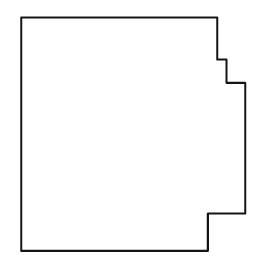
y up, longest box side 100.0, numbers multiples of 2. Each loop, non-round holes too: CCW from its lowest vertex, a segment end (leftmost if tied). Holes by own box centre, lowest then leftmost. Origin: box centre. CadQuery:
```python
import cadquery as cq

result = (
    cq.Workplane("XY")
    .moveTo(-48.0, -50.0)
    .lineTo(32.0, -50.0)
    .lineTo(32.0, -34.0)
    .lineTo(48.0, -34.0)
    .lineTo(48.0, 22.0)
    .lineTo(40.0, 22.0)
    .lineTo(40.0, 32.0)
    .lineTo(36.0, 32.0)
    .lineTo(36.0, 50.0)
    .lineTo(-48.0, 50.0)
    .close()
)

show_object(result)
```